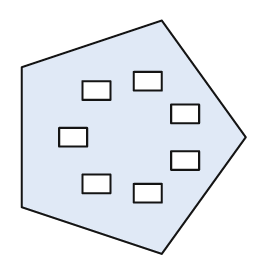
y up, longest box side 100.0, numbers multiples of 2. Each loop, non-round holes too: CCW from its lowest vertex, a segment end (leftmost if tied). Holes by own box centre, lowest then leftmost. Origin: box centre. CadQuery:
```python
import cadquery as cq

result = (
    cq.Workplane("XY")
    .moveTo(12.0, -50.0)
    .lineTo(48.0, 0.0)
    .lineTo(12.0, 50.0)
    .lineTo(-48.0, 30.0)
    .lineTo(-48.0, -30.0)
    .close()
    .moveTo(0.0, -28.0)
    .lineTo(12.0, -28.0)
    .lineTo(12.0, -20.0)
    .lineTo(0.0, -20.0)
    .close()
    .moveTo(-22.0, -24.0)
    .lineTo(-10.0, -24.0)
    .lineTo(-10.0, -16.0)
    .lineTo(-22.0, -16.0)
    .close()
    .moveTo(16.0, -14.0)
    .lineTo(28.0, -14.0)
    .lineTo(28.0, -6.0)
    .lineTo(16.0, -6.0)
    .close()
    .moveTo(-32.0, -4.0)
    .lineTo(-20.0, -4.0)
    .lineTo(-20.0, 4.0)
    .lineTo(-32.0, 4.0)
    .close()
    .moveTo(16.0, 6.0)
    .lineTo(28.0, 6.0)
    .lineTo(28.0, 14.0)
    .lineTo(16.0, 14.0)
    .close()
    .moveTo(-22.0, 16.0)
    .lineTo(-10.0, 16.0)
    .lineTo(-10.0, 24.0)
    .lineTo(-22.0, 24.0)
    .close()
    .moveTo(0.0, 20.0)
    .lineTo(12.0, 20.0)
    .lineTo(12.0, 28.0)
    .lineTo(0.0, 28.0)
    .close()
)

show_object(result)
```